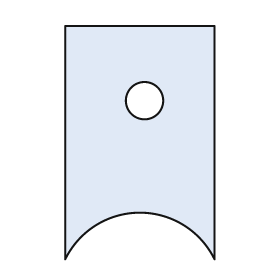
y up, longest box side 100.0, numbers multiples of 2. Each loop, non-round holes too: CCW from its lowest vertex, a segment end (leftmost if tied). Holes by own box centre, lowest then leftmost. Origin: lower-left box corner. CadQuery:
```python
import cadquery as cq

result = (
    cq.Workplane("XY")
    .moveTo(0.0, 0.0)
    .threePointArc((32.0, 20.0), (64.0, 0.0))
    .lineTo(64.0, 100.0)
    .lineTo(0.0, 100.0)
    .close()
    .moveTo(34.0, 68.0)
    .circle(8.0)
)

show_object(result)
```